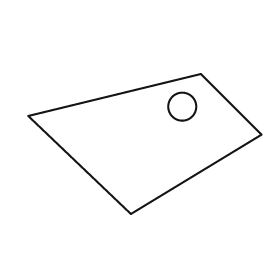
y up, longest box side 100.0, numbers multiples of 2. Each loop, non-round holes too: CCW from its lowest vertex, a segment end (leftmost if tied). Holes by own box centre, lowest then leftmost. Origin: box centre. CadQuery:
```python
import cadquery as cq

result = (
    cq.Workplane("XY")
    .moveTo(-6.0, -30.0)
    .lineTo(50.0, 4.0)
    .lineTo(24.0, 30.0)
    .lineTo(-50.0, 12.0)
    .close()
    .moveTo(16.0, 16.0)
    .circle(6.0)
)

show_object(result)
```